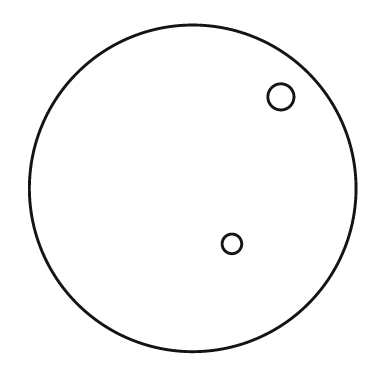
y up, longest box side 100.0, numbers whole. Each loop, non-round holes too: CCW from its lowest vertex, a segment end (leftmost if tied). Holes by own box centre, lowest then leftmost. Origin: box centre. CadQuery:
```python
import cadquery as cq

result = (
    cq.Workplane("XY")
    .moveTo(0.0, 0.0)
    .circle(50.0)
    .moveTo(12.0, -17.0)
    .circle(3.0)
    .moveTo(27.0, 28.0)
    .circle(4.0)
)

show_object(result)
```